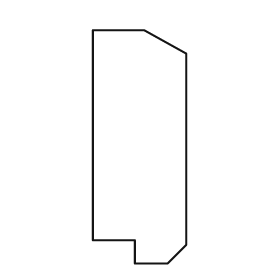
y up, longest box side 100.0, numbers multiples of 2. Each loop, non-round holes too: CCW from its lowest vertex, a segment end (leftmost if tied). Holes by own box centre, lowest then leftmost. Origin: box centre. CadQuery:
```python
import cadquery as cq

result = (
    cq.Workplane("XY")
    .moveTo(-2.0, -50.0)
    .lineTo(12.0, -50.0)
    .lineTo(20.0, -42.0)
    .lineTo(20.0, 40.0)
    .lineTo(2.0, 50.0)
    .lineTo(-20.0, 50.0)
    .lineTo(-20.0, -40.0)
    .lineTo(-2.0, -40.0)
    .close()
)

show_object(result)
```